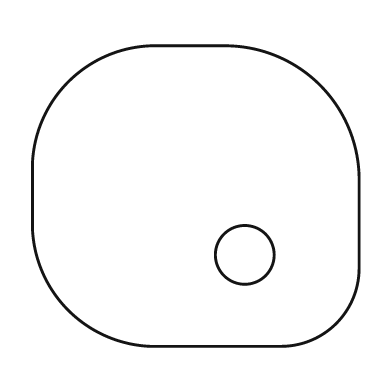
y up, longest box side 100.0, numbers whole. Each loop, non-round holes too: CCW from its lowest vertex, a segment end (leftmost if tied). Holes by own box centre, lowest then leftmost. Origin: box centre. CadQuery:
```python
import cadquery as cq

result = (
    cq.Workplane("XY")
    .moveTo(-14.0, -46.0)
    .lineTo(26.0, -46.0)
    .threePointArc((43.0, -39.0), (50.0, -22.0))
    .lineTo(50.0, 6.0)
    .threePointArc((38.0, 34.0), (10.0, 46.0))
    .lineTo(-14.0, 46.0)
    .threePointArc((-39.0, 35.0), (-50.0, 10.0))
    .lineTo(-50.0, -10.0)
    .threePointArc((-39.0, -35.0), (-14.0, -46.0))
    .close()
    .moveTo(15.0, -18.0)
    .circle(9.0)
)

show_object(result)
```